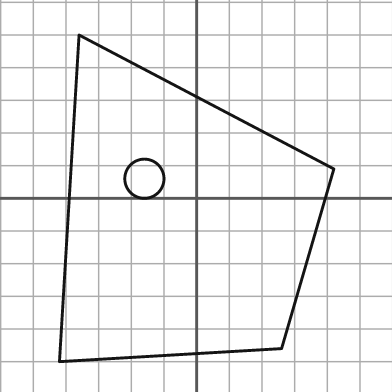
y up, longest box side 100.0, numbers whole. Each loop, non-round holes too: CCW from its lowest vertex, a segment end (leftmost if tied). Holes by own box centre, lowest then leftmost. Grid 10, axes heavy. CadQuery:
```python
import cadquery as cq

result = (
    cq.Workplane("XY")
    .moveTo(-42.0, -50.0)
    .lineTo(26.0, -46.0)
    .lineTo(42.0, 9.0)
    .lineTo(-36.0, 50.0)
    .close()
    .moveTo(-16.0, 6.0)
    .circle(6.0)
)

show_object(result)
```